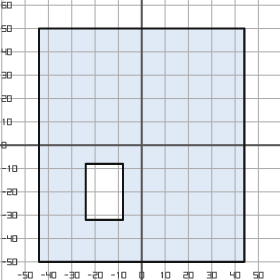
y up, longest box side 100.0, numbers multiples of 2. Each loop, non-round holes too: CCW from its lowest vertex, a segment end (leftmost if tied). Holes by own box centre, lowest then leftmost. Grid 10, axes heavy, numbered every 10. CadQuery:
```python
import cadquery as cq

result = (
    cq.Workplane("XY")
    .moveTo(-44.0, -50.0)
    .lineTo(44.0, -50.0)
    .lineTo(44.0, 50.0)
    .lineTo(-44.0, 50.0)
    .close()
    .moveTo(-24.0, -32.0)
    .lineTo(-8.0, -32.0)
    .lineTo(-8.0, -8.0)
    .lineTo(-24.0, -8.0)
    .close()
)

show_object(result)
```